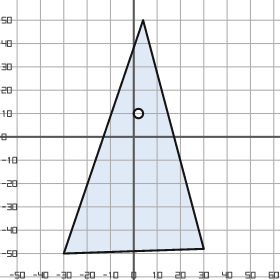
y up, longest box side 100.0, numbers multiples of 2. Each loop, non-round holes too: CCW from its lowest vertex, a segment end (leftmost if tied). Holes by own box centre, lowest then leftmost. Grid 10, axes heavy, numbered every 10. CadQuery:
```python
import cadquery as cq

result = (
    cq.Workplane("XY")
    .moveTo(-30.0, -50.0)
    .lineTo(30.0, -48.0)
    .lineTo(4.0, 50.0)
    .close()
    .moveTo(2.0, 10.0)
    .circle(2.0)
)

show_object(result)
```